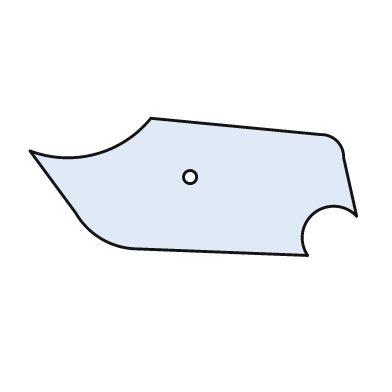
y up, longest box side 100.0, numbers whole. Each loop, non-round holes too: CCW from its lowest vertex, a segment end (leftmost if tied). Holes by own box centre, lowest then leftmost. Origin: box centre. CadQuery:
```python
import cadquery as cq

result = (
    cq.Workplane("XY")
    .moveTo(35.0, -21.0)
    .threePointArc((37.0, -8.0), (50.0, -9.0))
    .lineTo(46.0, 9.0)
    .threePointArc((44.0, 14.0), (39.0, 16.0))
    .lineTo(-13.0, 21.0)
    .threePointArc((-30.0, 10.0), (-50.0, 11.0))
    .lineTo(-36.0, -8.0)
    .threePointArc((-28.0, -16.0), (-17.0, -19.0))
    .close()
    .moveTo(-1.0, 3.0)
    .circle(2.0)
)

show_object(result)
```